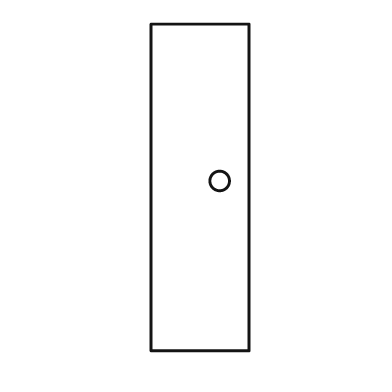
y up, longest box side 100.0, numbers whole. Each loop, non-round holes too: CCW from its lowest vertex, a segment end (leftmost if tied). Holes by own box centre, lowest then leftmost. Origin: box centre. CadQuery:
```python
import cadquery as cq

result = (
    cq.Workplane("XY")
    .moveTo(-15.0, -50.0)
    .lineTo(15.0, -50.0)
    .lineTo(15.0, 50.0)
    .lineTo(-15.0, 50.0)
    .close()
    .moveTo(6.0, 2.0)
    .circle(3.0)
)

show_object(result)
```